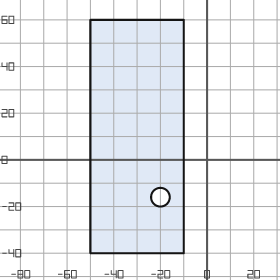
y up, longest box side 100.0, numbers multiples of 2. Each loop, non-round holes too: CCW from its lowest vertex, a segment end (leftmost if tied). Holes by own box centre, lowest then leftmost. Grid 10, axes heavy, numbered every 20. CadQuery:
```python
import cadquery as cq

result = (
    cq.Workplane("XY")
    .moveTo(-50.0, -40.0)
    .lineTo(-10.0, -40.0)
    .lineTo(-10.0, 60.0)
    .lineTo(-50.0, 60.0)
    .close()
    .moveTo(-20.0, -16.0)
    .circle(4.0)
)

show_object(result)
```